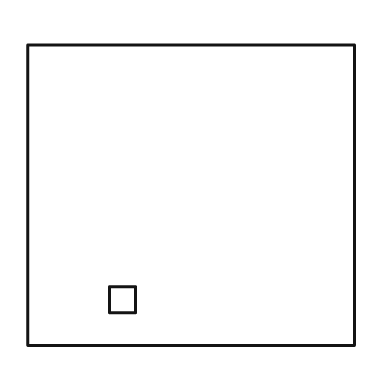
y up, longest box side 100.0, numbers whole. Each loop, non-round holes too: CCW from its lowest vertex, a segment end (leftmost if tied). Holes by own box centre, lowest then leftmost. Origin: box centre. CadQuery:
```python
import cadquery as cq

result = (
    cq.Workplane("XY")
    .moveTo(-50.0, -46.0)
    .lineTo(50.0, -46.0)
    .lineTo(50.0, 46.0)
    .lineTo(-50.0, 46.0)
    .close()
    .moveTo(-25.0, -36.0)
    .lineTo(-17.0, -36.0)
    .lineTo(-17.0, -28.0)
    .lineTo(-25.0, -28.0)
    .close()
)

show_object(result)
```